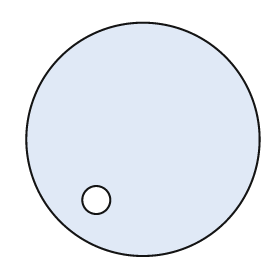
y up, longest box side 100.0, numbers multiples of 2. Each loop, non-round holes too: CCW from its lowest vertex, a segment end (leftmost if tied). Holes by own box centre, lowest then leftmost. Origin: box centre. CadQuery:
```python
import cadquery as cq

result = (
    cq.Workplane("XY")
    .moveTo(0.0, 0.0)
    .circle(50.0)
    .moveTo(-20.0, -26.0)
    .circle(6.0)
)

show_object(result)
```